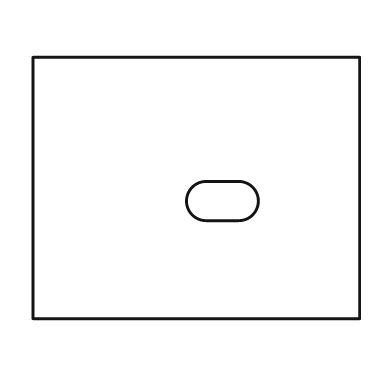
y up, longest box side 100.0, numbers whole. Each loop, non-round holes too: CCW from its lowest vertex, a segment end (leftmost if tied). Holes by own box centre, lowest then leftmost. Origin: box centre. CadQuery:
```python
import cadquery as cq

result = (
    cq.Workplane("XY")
    .moveTo(-50.0, -40.0)
    .lineTo(50.0, -40.0)
    .lineTo(50.0, 40.0)
    .lineTo(-50.0, 40.0)
    .close()
    .moveTo(3.0, -10.0)
    .lineTo(13.0, -10.0)
    .threePointArc((19.0, -4.0), (13.0, 2.0))
    .lineTo(3.0, 2.0)
    .threePointArc((-3.0, -4.0), (3.0, -10.0))
    .close()
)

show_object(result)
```